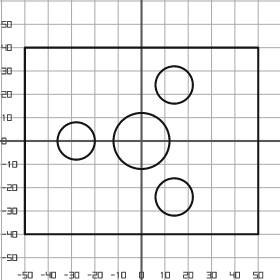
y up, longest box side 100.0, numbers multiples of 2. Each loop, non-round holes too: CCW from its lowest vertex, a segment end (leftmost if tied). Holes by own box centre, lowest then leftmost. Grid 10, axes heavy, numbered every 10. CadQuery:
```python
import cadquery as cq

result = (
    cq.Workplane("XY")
    .moveTo(-50.0, -40.0)
    .lineTo(50.0, -40.0)
    .lineTo(50.0, 40.0)
    .lineTo(-50.0, 40.0)
    .close()
    .moveTo(14.0, -24.0)
    .circle(8.0)
    .moveTo(-28.0, 0.0)
    .circle(8.0)
    .moveTo(0.0, 0.0)
    .circle(12.0)
    .moveTo(14.0, 24.0)
    .circle(8.0)
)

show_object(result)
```